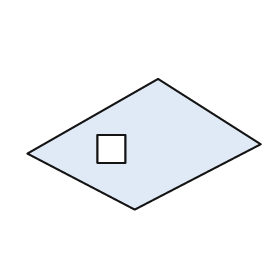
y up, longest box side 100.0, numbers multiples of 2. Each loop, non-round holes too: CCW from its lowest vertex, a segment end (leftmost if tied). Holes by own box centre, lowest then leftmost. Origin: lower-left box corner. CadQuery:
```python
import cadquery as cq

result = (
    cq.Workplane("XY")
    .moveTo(46.0, 0.0)
    .lineTo(100.0, 28.0)
    .lineTo(56.0, 56.0)
    .lineTo(0.0, 24.0)
    .close()
    .moveTo(30.0, 20.0)
    .lineTo(42.0, 20.0)
    .lineTo(42.0, 32.0)
    .lineTo(30.0, 32.0)
    .close()
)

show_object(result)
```